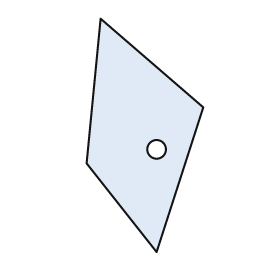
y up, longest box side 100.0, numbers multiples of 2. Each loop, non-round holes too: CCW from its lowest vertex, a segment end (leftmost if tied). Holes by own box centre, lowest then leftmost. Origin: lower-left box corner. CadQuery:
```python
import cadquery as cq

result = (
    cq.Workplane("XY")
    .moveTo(30.0, 0.0)
    .lineTo(50.0, 62.0)
    .lineTo(6.0, 100.0)
    .lineTo(0.0, 38.0)
    .close()
    .moveTo(30.0, 44.0)
    .circle(4.0)
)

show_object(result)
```